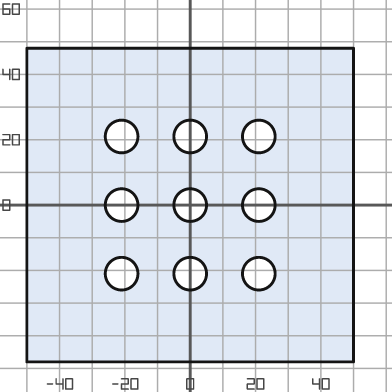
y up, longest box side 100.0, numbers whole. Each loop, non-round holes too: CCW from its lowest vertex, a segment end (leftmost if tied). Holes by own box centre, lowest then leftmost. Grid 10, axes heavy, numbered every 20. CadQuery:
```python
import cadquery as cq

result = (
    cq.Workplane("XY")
    .moveTo(-50.0, -48.0)
    .lineTo(50.0, -48.0)
    .lineTo(50.0, 48.0)
    .lineTo(-50.0, 48.0)
    .close()
    .moveTo(-21.0, -21.0)
    .circle(5.0)
    .moveTo(0.0, -21.0)
    .circle(5.0)
    .moveTo(21.0, -21.0)
    .circle(5.0)
    .moveTo(-21.0, 0.0)
    .circle(5.0)
    .moveTo(0.0, 0.0)
    .circle(5.0)
    .moveTo(21.0, 0.0)
    .circle(5.0)
    .moveTo(-21.0, 21.0)
    .circle(5.0)
    .moveTo(0.0, 21.0)
    .circle(5.0)
    .moveTo(21.0, 21.0)
    .circle(5.0)
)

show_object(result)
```